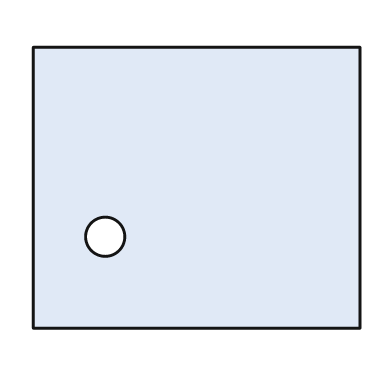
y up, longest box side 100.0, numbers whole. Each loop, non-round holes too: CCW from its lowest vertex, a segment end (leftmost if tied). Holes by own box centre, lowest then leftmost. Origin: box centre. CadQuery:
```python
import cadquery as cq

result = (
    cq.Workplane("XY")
    .moveTo(-50.0, -43.0)
    .lineTo(50.0, -43.0)
    .lineTo(50.0, 43.0)
    .lineTo(-50.0, 43.0)
    .close()
    .moveTo(-28.0, -15.0)
    .circle(6.0)
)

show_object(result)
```